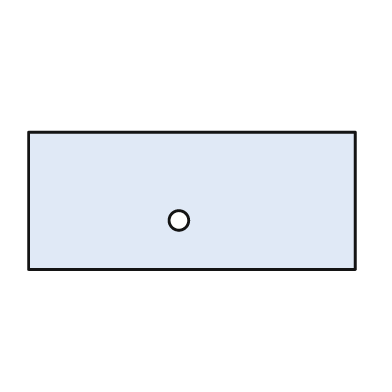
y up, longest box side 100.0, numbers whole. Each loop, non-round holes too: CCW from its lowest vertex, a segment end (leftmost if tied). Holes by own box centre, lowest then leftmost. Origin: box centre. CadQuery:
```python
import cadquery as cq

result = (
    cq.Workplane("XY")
    .moveTo(-50.0, -21.0)
    .lineTo(50.0, -21.0)
    .lineTo(50.0, 21.0)
    .lineTo(-50.0, 21.0)
    .close()
    .moveTo(-4.0, -6.0)
    .circle(3.0)
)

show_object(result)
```